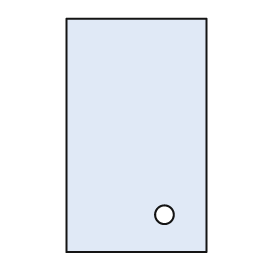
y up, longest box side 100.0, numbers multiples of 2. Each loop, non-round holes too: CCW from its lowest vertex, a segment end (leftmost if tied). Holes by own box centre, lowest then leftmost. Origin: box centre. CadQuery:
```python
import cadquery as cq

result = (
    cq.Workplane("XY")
    .moveTo(-30.0, -50.0)
    .lineTo(30.0, -50.0)
    .lineTo(30.0, 50.0)
    .lineTo(-30.0, 50.0)
    .close()
    .moveTo(12.0, -34.0)
    .circle(4.0)
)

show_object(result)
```